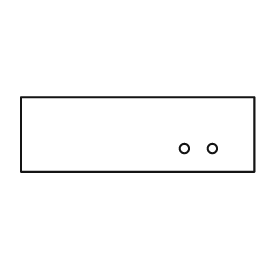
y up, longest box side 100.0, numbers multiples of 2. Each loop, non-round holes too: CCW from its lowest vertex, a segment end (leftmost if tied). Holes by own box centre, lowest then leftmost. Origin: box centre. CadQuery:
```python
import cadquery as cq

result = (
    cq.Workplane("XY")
    .moveTo(-50.0, -16.0)
    .lineTo(50.0, -16.0)
    .lineTo(50.0, 16.0)
    .lineTo(-50.0, 16.0)
    .close()
    .moveTo(20.0, -6.0)
    .circle(2.0)
    .moveTo(32.0, -6.0)
    .circle(2.0)
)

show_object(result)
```